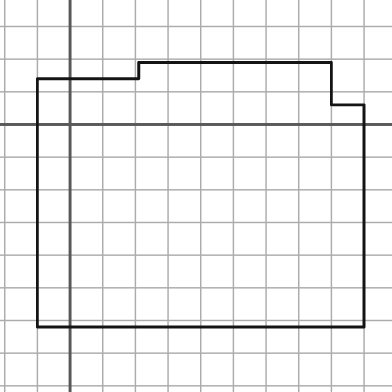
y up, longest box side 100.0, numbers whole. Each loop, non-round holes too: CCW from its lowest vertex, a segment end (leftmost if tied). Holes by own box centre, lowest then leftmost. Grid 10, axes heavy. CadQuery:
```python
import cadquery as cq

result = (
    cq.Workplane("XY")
    .moveTo(-10.0, -62.0)
    .lineTo(90.0, -62.0)
    .lineTo(90.0, 6.0)
    .lineTo(80.0, 6.0)
    .lineTo(80.0, 19.0)
    .lineTo(21.0, 19.0)
    .lineTo(21.0, 14.0)
    .lineTo(-10.0, 14.0)
    .close()
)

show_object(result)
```